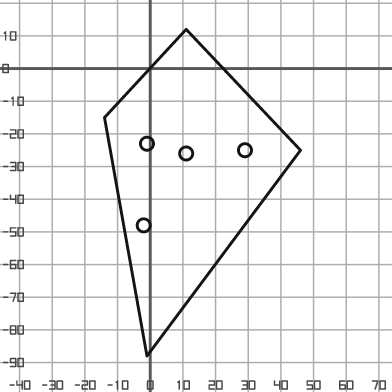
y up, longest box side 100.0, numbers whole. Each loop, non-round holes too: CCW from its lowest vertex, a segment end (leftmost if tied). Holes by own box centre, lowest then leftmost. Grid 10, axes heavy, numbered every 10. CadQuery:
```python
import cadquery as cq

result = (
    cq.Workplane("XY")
    .moveTo(-1.0, -88.0)
    .lineTo(46.0, -25.0)
    .lineTo(11.0, 12.0)
    .lineTo(-14.0, -15.0)
    .close()
    .moveTo(-2.0, -48.0)
    .circle(2.0)
    .moveTo(11.0, -26.0)
    .circle(2.0)
    .moveTo(29.0, -25.0)
    .circle(2.0)
    .moveTo(-1.0, -23.0)
    .circle(2.0)
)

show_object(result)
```